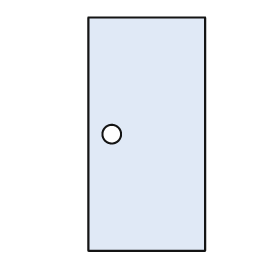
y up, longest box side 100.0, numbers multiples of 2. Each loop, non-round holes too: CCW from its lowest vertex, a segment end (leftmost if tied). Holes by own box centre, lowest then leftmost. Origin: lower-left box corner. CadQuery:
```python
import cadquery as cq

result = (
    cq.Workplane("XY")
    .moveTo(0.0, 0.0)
    .lineTo(50.0, 0.0)
    .lineTo(50.0, 100.0)
    .lineTo(0.0, 100.0)
    .close()
    .moveTo(10.0, 50.0)
    .circle(4.0)
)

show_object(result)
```